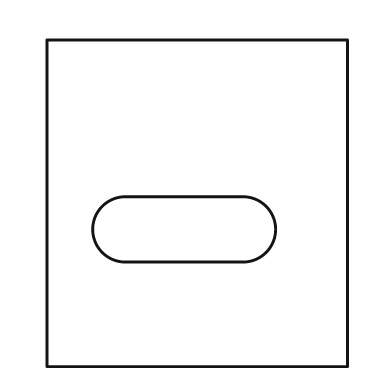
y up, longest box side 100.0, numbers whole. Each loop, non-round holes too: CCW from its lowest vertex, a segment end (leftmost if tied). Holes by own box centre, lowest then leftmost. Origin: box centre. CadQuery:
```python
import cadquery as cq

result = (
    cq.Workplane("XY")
    .moveTo(-46.0, -50.0)
    .lineTo(46.0, -50.0)
    .lineTo(46.0, 50.0)
    .lineTo(-46.0, 50.0)
    .close()
    .moveTo(-22.0, -18.0)
    .lineTo(14.0, -18.0)
    .threePointArc((24.0, -8.0), (14.0, 2.0))
    .lineTo(-22.0, 2.0)
    .threePointArc((-32.0, -8.0), (-22.0, -18.0))
    .close()
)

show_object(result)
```